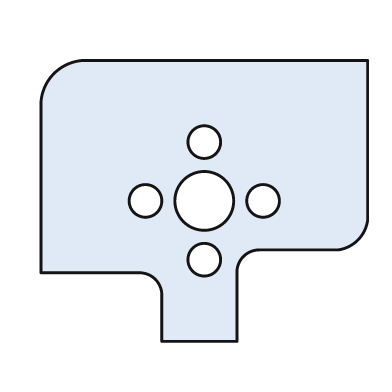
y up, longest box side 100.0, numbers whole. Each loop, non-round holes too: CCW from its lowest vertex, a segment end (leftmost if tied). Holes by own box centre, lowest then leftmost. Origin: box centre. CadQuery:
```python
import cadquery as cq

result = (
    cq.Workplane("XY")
    .moveTo(-13.0, -43.0)
    .lineTo(10.0, -43.0)
    .lineTo(10.0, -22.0)
    .threePointArc((12.0, -17.0), (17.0, -15.0))
    .lineTo(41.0, -15.0)
    .threePointArc((47.0, -12.0), (50.0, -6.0))
    .lineTo(50.0, 43.0)
    .lineTo(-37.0, 43.0)
    .threePointArc((-46.0, 39.0), (-50.0, 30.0))
    .lineTo(-50.0, -22.0)
    .lineTo(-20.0, -22.0)
    .threePointArc((-15.0, -24.0), (-13.0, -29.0))
    .close()
    .moveTo(0.0, -18.0)
    .circle(5.0)
    .moveTo(-18.0, 0.0)
    .circle(5.0)
    .moveTo(0.0, 0.0)
    .circle(9.0)
    .moveTo(18.0, 0.0)
    .circle(5.0)
    .moveTo(0.0, 18.0)
    .circle(5.0)
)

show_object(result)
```